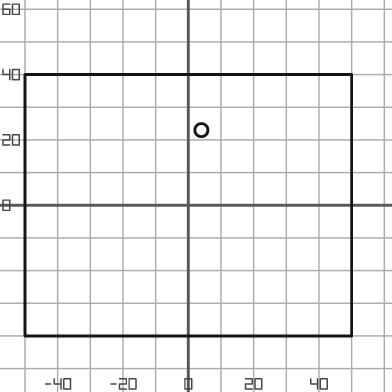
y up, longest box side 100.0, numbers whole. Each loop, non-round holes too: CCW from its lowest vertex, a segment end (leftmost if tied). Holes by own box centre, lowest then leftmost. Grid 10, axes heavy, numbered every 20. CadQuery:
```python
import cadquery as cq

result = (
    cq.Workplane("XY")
    .moveTo(-50.0, -40.0)
    .lineTo(50.0, -40.0)
    .lineTo(50.0, 40.0)
    .lineTo(-50.0, 40.0)
    .close()
    .moveTo(4.0, 23.0)
    .circle(2.0)
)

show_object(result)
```